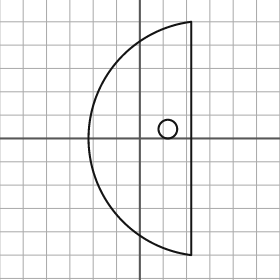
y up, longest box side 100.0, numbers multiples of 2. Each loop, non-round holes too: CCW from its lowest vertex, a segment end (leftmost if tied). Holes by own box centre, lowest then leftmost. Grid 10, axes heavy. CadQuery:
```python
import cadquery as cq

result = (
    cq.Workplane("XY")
    .moveTo(22.0, -50.0)
    .lineTo(22.0, 50.0)
    .threePointArc((-22.0, 0.0), (22.0, -50.0))
    .close()
    .moveTo(12.0, 4.0)
    .circle(4.0)
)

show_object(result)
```